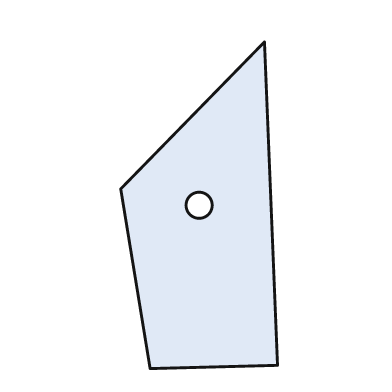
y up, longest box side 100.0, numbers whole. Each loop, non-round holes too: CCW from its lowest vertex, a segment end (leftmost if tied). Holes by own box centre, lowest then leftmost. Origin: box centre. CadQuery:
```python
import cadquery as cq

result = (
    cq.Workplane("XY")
    .moveTo(-15.0, -50.0)
    .lineTo(24.0, -49.0)
    .lineTo(20.0, 50.0)
    .lineTo(-24.0, 5.0)
    .close()
    .moveTo(0.0, 0.0)
    .circle(4.0)
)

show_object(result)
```